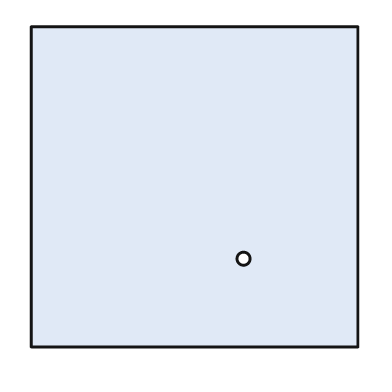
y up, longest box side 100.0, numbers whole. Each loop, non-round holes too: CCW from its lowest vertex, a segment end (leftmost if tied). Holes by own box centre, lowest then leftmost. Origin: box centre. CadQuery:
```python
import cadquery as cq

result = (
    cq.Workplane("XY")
    .moveTo(-50.0, -49.0)
    .lineTo(50.0, -49.0)
    .lineTo(50.0, 49.0)
    .lineTo(-50.0, 49.0)
    .close()
    .moveTo(15.0, -22.0)
    .circle(2.0)
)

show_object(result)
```